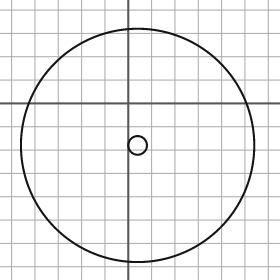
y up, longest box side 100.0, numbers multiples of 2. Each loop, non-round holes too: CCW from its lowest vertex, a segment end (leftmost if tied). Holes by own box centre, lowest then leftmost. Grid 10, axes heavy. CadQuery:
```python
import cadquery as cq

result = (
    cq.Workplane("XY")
    .moveTo(4.0, -18.0)
    .circle(50.0)
    .moveTo(4.0, -18.0)
    .circle(4.0)
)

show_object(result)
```